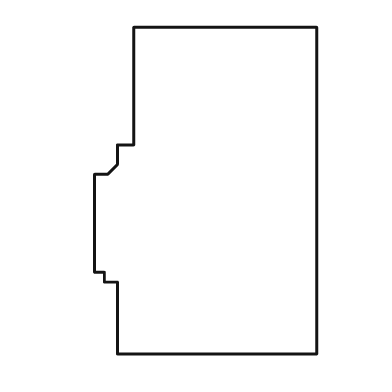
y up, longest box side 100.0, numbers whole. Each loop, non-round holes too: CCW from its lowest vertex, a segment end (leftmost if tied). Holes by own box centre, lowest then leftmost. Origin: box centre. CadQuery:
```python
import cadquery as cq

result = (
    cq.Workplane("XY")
    .moveTo(-27.0, -50.0)
    .lineTo(34.0, -50.0)
    .lineTo(34.0, 50.0)
    .lineTo(-22.0, 50.0)
    .lineTo(-22.0, 14.0)
    .lineTo(-27.0, 14.0)
    .lineTo(-27.0, 8.0)
    .lineTo(-30.0, 5.0)
    .lineTo(-34.0, 5.0)
    .lineTo(-34.0, -25.0)
    .lineTo(-31.0, -25.0)
    .lineTo(-31.0, -28.0)
    .lineTo(-27.0, -28.0)
    .close()
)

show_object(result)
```